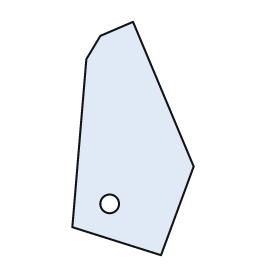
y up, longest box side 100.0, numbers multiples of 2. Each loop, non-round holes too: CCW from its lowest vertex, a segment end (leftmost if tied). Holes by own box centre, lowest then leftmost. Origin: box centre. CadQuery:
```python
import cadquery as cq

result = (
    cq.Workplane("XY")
    .moveTo(12.0, -50.0)
    .lineTo(26.0, -12.0)
    .lineTo(0.0, 50.0)
    .lineTo(-14.0, 44.0)
    .lineTo(-20.0, 34.0)
    .lineTo(-26.0, -38.0)
    .close()
    .moveTo(-10.0, -28.0)
    .circle(4.0)
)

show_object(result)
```